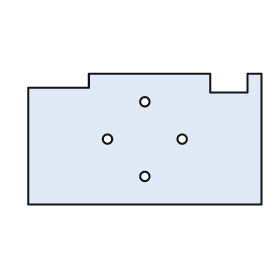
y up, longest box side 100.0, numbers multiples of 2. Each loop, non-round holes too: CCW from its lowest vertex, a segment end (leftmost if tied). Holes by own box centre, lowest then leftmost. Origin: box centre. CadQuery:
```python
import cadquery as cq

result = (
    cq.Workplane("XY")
    .moveTo(-50.0, -28.0)
    .lineTo(50.0, -28.0)
    .lineTo(50.0, 28.0)
    .lineTo(44.0, 28.0)
    .lineTo(44.0, 20.0)
    .lineTo(28.0, 20.0)
    .lineTo(28.0, 28.0)
    .lineTo(-24.0, 28.0)
    .lineTo(-24.0, 22.0)
    .lineTo(-50.0, 22.0)
    .close()
    .moveTo(0.0, -16.0)
    .circle(2.0)
    .moveTo(-16.0, 0.0)
    .circle(2.0)
    .moveTo(16.0, 0.0)
    .circle(2.0)
    .moveTo(0.0, 16.0)
    .circle(2.0)
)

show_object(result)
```